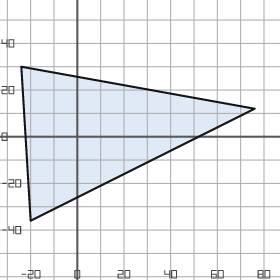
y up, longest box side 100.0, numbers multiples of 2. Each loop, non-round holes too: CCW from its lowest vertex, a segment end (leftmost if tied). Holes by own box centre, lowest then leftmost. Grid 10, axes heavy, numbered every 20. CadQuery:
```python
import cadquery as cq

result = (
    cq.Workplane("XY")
    .moveTo(-20.0, -36.0)
    .lineTo(76.0, 12.0)
    .lineTo(-24.0, 30.0)
    .close()
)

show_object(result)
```